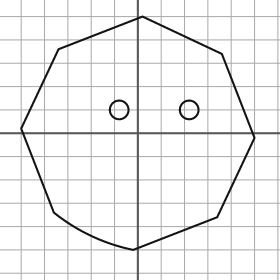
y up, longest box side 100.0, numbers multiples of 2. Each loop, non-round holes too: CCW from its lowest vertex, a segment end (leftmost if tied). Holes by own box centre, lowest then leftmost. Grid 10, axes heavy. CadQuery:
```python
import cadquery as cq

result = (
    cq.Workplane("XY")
    .moveTo(-2.0, -50.0)
    .lineTo(34.0, -36.0)
    .lineTo(50.0, -2.0)
    .lineTo(36.0, 34.0)
    .lineTo(2.0, 50.0)
    .lineTo(-34.0, 36.0)
    .lineTo(-50.0, 2.0)
    .lineTo(-36.0, -34.0)
    .threePointArc((-20.0, -44.0), (-2.0, -50.0))
    .close()
    .moveTo(-8.0, 10.0)
    .circle(4.0)
    .moveTo(22.0, 10.0)
    .circle(4.0)
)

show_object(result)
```